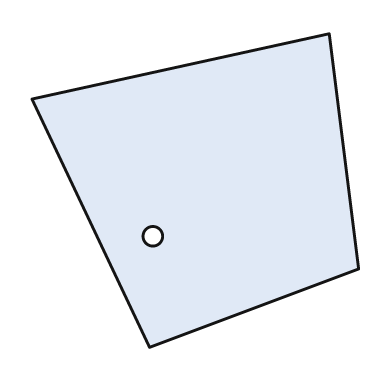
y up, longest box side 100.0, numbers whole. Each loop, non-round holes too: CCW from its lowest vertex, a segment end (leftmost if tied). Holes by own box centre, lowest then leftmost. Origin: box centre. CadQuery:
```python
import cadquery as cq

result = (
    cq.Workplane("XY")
    .moveTo(-14.0, -48.0)
    .lineTo(50.0, -24.0)
    .lineTo(41.0, 48.0)
    .lineTo(-50.0, 28.0)
    .close()
    .moveTo(-13.0, -14.0)
    .circle(3.0)
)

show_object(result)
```